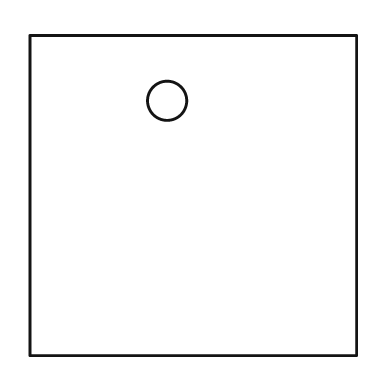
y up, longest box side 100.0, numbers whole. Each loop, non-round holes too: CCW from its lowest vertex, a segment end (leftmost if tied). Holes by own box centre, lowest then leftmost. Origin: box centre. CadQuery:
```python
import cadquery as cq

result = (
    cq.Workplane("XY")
    .moveTo(-50.0, -49.0)
    .lineTo(50.0, -49.0)
    .lineTo(50.0, 49.0)
    .lineTo(-50.0, 49.0)
    .close()
    .moveTo(-8.0, 29.0)
    .circle(6.0)
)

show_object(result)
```